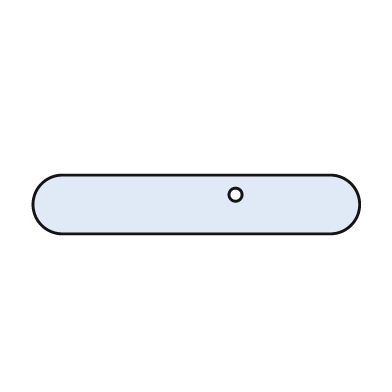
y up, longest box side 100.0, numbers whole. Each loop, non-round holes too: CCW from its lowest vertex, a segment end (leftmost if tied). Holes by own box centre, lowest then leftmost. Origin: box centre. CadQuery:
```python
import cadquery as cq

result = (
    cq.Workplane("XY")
    .moveTo(-41.0, -9.0)
    .lineTo(41.0, -9.0)
    .threePointArc((50.0, 0.0), (41.0, 9.0))
    .lineTo(-41.0, 9.0)
    .threePointArc((-50.0, 0.0), (-41.0, -9.0))
    .close()
    .moveTo(12.0, 3.0)
    .circle(2.0)
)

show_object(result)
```